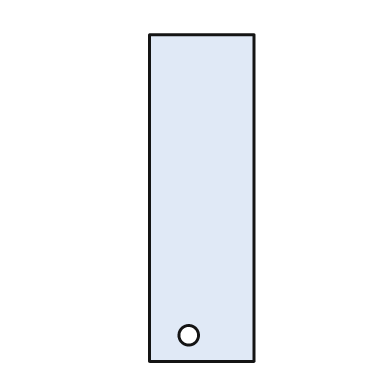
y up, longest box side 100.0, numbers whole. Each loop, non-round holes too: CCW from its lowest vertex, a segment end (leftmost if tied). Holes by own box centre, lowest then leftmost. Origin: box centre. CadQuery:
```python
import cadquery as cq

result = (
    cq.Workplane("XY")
    .moveTo(-16.0, -50.0)
    .lineTo(16.0, -50.0)
    .lineTo(16.0, 50.0)
    .lineTo(-16.0, 50.0)
    .close()
    .moveTo(-4.0, -42.0)
    .circle(3.0)
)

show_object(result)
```